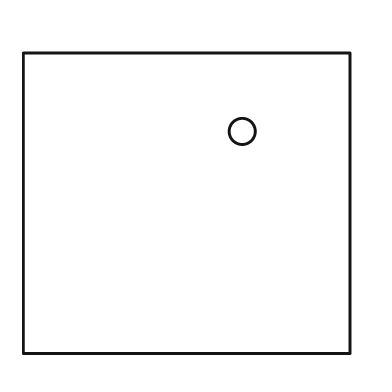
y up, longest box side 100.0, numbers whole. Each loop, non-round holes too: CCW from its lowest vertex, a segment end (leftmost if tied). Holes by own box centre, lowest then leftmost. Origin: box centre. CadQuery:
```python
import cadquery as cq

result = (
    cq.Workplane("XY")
    .moveTo(-50.0, -46.0)
    .lineTo(50.0, -46.0)
    .lineTo(50.0, 46.0)
    .lineTo(-50.0, 46.0)
    .close()
    .moveTo(17.0, 22.0)
    .circle(4.0)
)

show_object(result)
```